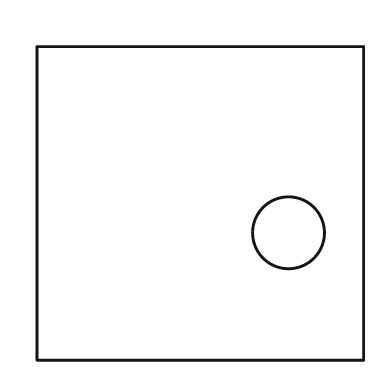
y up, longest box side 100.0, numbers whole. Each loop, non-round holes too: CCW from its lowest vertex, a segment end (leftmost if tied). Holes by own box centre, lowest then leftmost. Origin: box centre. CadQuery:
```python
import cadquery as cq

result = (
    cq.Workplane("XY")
    .moveTo(-50.0, -48.0)
    .lineTo(50.0, -48.0)
    .lineTo(50.0, 48.0)
    .lineTo(-50.0, 48.0)
    .close()
    .moveTo(27.0, -9.0)
    .circle(11.0)
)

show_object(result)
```